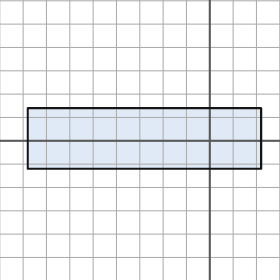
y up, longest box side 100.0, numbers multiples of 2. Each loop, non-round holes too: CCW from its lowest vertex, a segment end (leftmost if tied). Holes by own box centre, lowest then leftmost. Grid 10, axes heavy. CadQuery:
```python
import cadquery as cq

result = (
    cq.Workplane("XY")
    .moveTo(-78.0, -12.0)
    .lineTo(22.0, -12.0)
    .lineTo(22.0, 14.0)
    .lineTo(-78.0, 14.0)
    .close()
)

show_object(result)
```